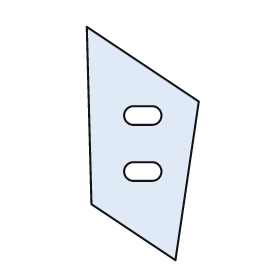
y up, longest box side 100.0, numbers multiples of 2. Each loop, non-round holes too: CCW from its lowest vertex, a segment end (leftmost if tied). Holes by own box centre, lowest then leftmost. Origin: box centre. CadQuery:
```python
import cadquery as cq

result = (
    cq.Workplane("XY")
    .moveTo(14.0, -50.0)
    .lineTo(24.0, 18.0)
    .lineTo(-24.0, 50.0)
    .lineTo(-22.0, -26.0)
    .close()
    .moveTo(-4.0, -16.0)
    .lineTo(4.0, -16.0)
    .threePointArc((8.0, -12.0), (4.0, -8.0))
    .lineTo(-4.0, -8.0)
    .threePointArc((-8.0, -12.0), (-4.0, -16.0))
    .close()
    .moveTo(-4.0, 8.0)
    .lineTo(4.0, 8.0)
    .threePointArc((8.0, 12.0), (4.0, 16.0))
    .lineTo(-4.0, 16.0)
    .threePointArc((-8.0, 12.0), (-4.0, 8.0))
    .close()
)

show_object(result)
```